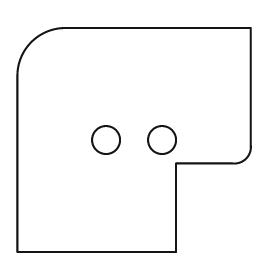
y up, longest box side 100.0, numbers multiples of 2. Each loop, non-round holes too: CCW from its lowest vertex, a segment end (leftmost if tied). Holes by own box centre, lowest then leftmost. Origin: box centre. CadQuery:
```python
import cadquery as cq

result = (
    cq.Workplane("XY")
    .moveTo(-50.0, -48.0)
    .lineTo(18.0, -48.0)
    .lineTo(18.0, -10.0)
    .lineTo(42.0, -10.0)
    .threePointArc((48.0, -8.0), (50.0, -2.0))
    .lineTo(50.0, 48.0)
    .lineTo(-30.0, 48.0)
    .threePointArc((-44.0, 42.0), (-50.0, 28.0))
    .close()
    .moveTo(-12.0, 0.0)
    .circle(6.0)
    .moveTo(12.0, 0.0)
    .circle(6.0)
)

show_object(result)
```